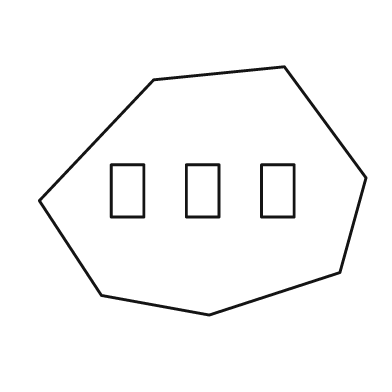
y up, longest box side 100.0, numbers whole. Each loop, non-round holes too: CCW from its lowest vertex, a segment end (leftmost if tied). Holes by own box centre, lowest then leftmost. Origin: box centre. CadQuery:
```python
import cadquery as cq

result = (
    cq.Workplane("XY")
    .moveTo(2.0, -38.0)
    .lineTo(42.0, -25.0)
    .lineTo(50.0, 4.0)
    .lineTo(25.0, 38.0)
    .lineTo(-15.0, 34.0)
    .lineTo(-50.0, -3.0)
    .lineTo(-31.0, -32.0)
    .close()
    .moveTo(-28.0, -8.0)
    .lineTo(-18.0, -8.0)
    .lineTo(-18.0, 8.0)
    .lineTo(-28.0, 8.0)
    .close()
    .moveTo(-5.0, -8.0)
    .lineTo(5.0, -8.0)
    .lineTo(5.0, 8.0)
    .lineTo(-5.0, 8.0)
    .close()
    .moveTo(18.0, -8.0)
    .lineTo(28.0, -8.0)
    .lineTo(28.0, 8.0)
    .lineTo(18.0, 8.0)
    .close()
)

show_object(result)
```